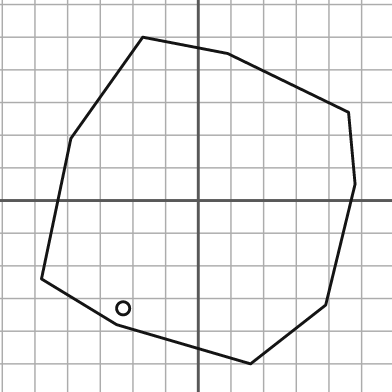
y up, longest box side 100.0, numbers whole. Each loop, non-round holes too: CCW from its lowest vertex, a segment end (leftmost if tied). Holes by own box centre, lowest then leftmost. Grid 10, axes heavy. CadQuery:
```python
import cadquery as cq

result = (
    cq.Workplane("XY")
    .moveTo(16.0, -50.0)
    .lineTo(39.0, -32.0)
    .lineTo(48.0, 5.0)
    .lineTo(46.0, 27.0)
    .lineTo(9.0, 45.0)
    .lineTo(-17.0, 50.0)
    .lineTo(-39.0, 19.0)
    .lineTo(-48.0, -24.0)
    .lineTo(-25.0, -38.0)
    .close()
    .moveTo(-23.0, -33.0)
    .circle(2.0)
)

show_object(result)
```